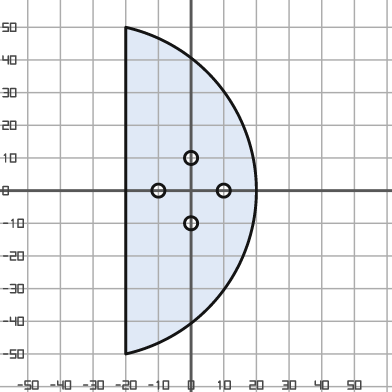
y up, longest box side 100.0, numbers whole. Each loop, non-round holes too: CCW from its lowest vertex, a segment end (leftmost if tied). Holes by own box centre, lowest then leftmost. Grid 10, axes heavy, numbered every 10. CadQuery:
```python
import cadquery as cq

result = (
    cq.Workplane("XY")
    .moveTo(-20.0, -50.0)
    .threePointArc((20.0, 0.0), (-20.0, 50.0))
    .close()
    .moveTo(0.0, -10.0)
    .circle(2.0)
    .moveTo(-10.0, 0.0)
    .circle(2.0)
    .moveTo(10.0, 0.0)
    .circle(2.0)
    .moveTo(0.0, 10.0)
    .circle(2.0)
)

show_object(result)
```